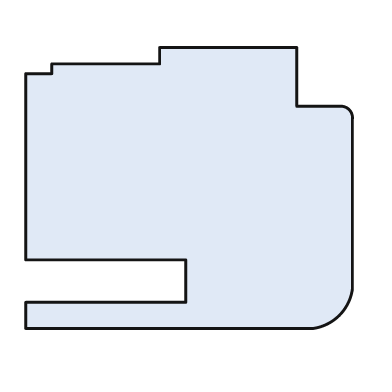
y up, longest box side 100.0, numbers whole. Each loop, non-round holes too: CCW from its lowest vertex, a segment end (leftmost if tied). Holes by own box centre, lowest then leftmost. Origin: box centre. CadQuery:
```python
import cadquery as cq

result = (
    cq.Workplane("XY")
    .moveTo(-50.0, -43.0)
    .lineTo(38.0, -43.0)
    .threePointArc((46.0, -39.0), (50.0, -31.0))
    .lineTo(50.0, 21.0)
    .threePointArc((49.0, 24.0), (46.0, 25.0))
    .lineTo(33.0, 25.0)
    .lineTo(33.0, 43.0)
    .lineTo(-9.0, 43.0)
    .lineTo(-9.0, 38.0)
    .lineTo(-42.0, 38.0)
    .lineTo(-42.0, 35.0)
    .lineTo(-50.0, 35.0)
    .lineTo(-50.0, -22.0)
    .lineTo(-1.0, -22.0)
    .lineTo(-1.0, -35.0)
    .lineTo(-50.0, -35.0)
    .close()
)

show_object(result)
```